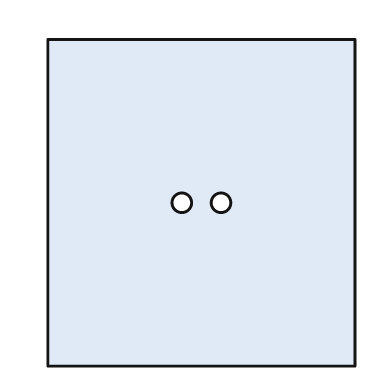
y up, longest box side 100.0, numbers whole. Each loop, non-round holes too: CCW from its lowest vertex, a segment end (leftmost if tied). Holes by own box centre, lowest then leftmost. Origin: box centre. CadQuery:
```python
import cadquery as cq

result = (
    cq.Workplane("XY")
    .moveTo(-47.0, -50.0)
    .lineTo(47.0, -50.0)
    .lineTo(47.0, 50.0)
    .lineTo(-47.0, 50.0)
    .close()
    .moveTo(-6.0, 0.0)
    .circle(3.0)
    .moveTo(6.0, 0.0)
    .circle(3.0)
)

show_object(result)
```